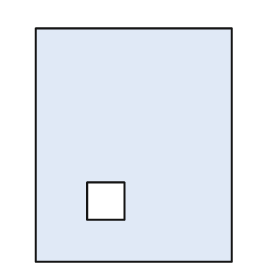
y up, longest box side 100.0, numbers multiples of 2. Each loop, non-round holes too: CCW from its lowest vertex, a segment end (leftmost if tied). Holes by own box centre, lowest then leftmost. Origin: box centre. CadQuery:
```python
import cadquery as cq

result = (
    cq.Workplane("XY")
    .moveTo(-42.0, -50.0)
    .lineTo(42.0, -50.0)
    .lineTo(42.0, 50.0)
    .lineTo(-42.0, 50.0)
    .close()
    .moveTo(-20.0, -32.0)
    .lineTo(-4.0, -32.0)
    .lineTo(-4.0, -16.0)
    .lineTo(-20.0, -16.0)
    .close()
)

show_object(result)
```